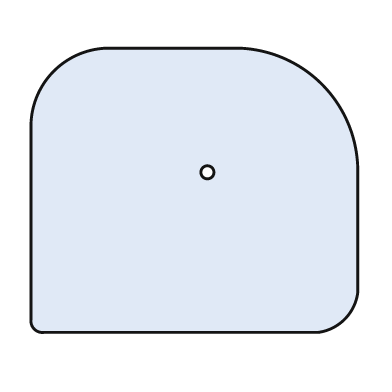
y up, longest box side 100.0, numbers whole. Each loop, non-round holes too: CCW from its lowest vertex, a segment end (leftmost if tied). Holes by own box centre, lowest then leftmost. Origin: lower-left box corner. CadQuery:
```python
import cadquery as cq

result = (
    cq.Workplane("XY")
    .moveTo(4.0, 0.0)
    .lineTo(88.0, 0.0)
    .threePointArc((96.0, 4.0), (100.0, 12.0))
    .lineTo(100.0, 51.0)
    .threePointArc((89.0, 76.0), (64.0, 87.0))
    .lineTo(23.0, 87.0)
    .threePointArc((7.0, 80.0), (0.0, 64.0))
    .lineTo(0.0, 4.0)
    .threePointArc((1.0, 1.0), (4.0, 0.0))
    .close()
    .moveTo(54.0, 49.0)
    .circle(2.0)
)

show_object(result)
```